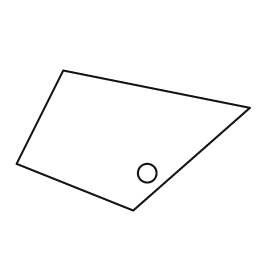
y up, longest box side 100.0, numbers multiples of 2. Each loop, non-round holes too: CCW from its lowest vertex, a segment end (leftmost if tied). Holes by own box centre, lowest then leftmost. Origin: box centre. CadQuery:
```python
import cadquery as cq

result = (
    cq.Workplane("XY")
    .moveTo(0.0, -30.0)
    .lineTo(50.0, 14.0)
    .lineTo(-30.0, 30.0)
    .lineTo(-50.0, -10.0)
    .close()
    .moveTo(6.0, -14.0)
    .circle(4.0)
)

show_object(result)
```